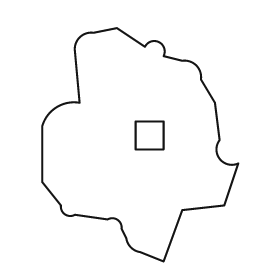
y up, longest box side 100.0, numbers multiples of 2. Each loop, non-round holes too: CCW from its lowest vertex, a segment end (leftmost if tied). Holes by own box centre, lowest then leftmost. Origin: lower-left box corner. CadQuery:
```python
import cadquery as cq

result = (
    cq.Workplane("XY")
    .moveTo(52.0, 0.0)
    .lineTo(60.0, 22.0)
    .lineTo(78.0, 24.0)
    .lineTo(84.0, 42.0)
    .threePointArc((76.0, 44.0), (76.0, 52.0))
    .lineTo(74.0, 68.0)
    .lineTo(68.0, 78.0)
    .threePointArc((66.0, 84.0), (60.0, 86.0))
    .lineTo(52.0, 88.0)
    .threePointArc((50.0, 94.0), (44.0, 92.0))
    .lineTo(32.0, 100.0)
    .lineTo(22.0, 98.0)
    .threePointArc((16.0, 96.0), (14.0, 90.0))
    .lineTo(16.0, 68.0)
    .threePointArc((6.0, 66.0), (0.0, 58.0))
    .lineTo(0.0, 34.0)
    .lineTo(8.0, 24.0)
    .threePointArc((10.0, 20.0), (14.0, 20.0))
    .lineTo(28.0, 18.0)
    .threePointArc((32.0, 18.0), (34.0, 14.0))
    .lineTo(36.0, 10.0)
    .threePointArc((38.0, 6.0), (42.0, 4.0))
    .close()
    .moveTo(40.0, 48.0)
    .lineTo(52.0, 48.0)
    .lineTo(52.0, 60.0)
    .lineTo(40.0, 60.0)
    .close()
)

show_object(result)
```